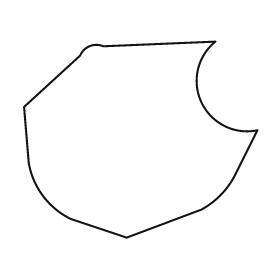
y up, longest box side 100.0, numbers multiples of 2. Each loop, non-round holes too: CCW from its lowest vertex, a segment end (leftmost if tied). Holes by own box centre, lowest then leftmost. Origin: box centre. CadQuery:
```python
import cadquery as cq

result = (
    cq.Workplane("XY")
    .moveTo(-6.0, -42.0)
    .lineTo(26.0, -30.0)
    .threePointArc((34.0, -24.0), (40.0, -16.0))
    .lineTo(50.0, 4.0)
    .threePointArc((26.0, 16.0), (32.0, 42.0))
    .lineTo(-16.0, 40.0)
    .threePointArc((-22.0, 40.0), (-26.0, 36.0))
    .lineTo(-50.0, 14.0)
    .lineTo(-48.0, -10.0)
    .threePointArc((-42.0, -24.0), (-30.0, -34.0))
    .close()
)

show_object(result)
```